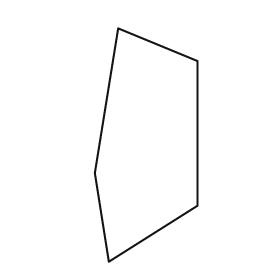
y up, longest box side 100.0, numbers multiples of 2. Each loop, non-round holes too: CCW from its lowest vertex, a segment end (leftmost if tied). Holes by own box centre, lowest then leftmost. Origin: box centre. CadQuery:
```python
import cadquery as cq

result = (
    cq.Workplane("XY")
    .moveTo(-16.0, -50.0)
    .lineTo(22.0, -26.0)
    .lineTo(22.0, 36.0)
    .lineTo(-12.0, 50.0)
    .lineTo(-22.0, -12.0)
    .close()
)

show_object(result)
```